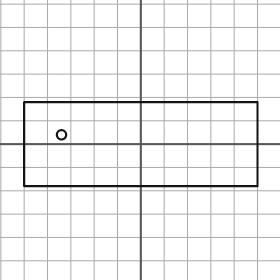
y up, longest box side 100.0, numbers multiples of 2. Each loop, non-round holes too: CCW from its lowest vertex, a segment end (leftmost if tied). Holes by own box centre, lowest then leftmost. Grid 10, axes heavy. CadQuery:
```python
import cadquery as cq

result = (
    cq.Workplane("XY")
    .moveTo(-50.0, -18.0)
    .lineTo(50.0, -18.0)
    .lineTo(50.0, 18.0)
    .lineTo(-50.0, 18.0)
    .close()
    .moveTo(-34.0, 4.0)
    .circle(2.0)
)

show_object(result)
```